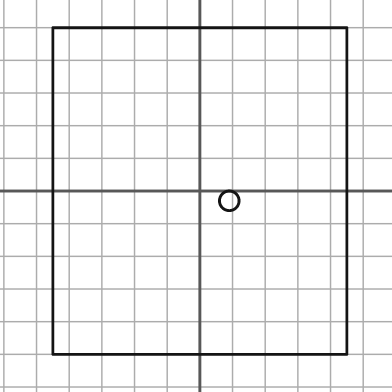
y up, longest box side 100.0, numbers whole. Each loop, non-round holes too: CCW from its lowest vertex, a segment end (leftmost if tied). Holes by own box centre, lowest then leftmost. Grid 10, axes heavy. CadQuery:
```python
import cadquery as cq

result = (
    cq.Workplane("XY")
    .moveTo(-45.0, -50.0)
    .lineTo(45.0, -50.0)
    .lineTo(45.0, 50.0)
    .lineTo(-45.0, 50.0)
    .close()
    .moveTo(9.0, -3.0)
    .circle(3.0)
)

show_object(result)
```